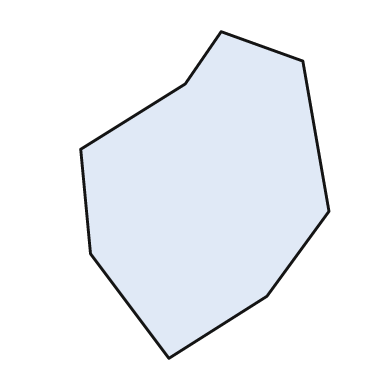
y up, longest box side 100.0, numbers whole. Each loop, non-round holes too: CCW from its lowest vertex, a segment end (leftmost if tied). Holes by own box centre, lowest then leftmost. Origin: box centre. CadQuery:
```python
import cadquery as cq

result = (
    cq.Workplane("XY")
    .moveTo(-11.0, -50.0)
    .lineTo(19.0, -31.0)
    .lineTo(38.0, -5.0)
    .lineTo(30.0, 41.0)
    .lineTo(5.0, 50.0)
    .lineTo(-6.0, 34.0)
    .lineTo(-38.0, 14.0)
    .lineTo(-35.0, -18.0)
    .close()
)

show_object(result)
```